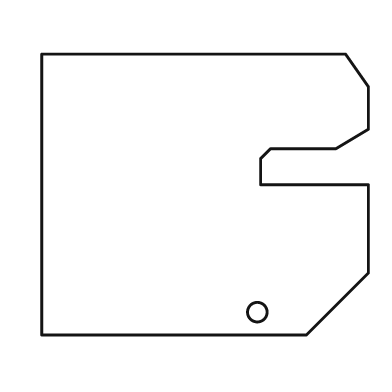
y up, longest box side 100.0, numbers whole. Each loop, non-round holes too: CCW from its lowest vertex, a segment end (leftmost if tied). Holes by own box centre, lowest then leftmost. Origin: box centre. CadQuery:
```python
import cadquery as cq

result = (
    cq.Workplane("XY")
    .moveTo(-50.0, -43.0)
    .lineTo(31.0, -43.0)
    .lineTo(50.0, -24.0)
    .lineTo(50.0, 3.0)
    .lineTo(17.0, 3.0)
    .lineTo(17.0, 11.0)
    .lineTo(20.0, 14.0)
    .lineTo(40.0, 14.0)
    .lineTo(50.0, 20.0)
    .lineTo(50.0, 33.0)
    .lineTo(43.0, 43.0)
    .lineTo(-50.0, 43.0)
    .close()
    .moveTo(16.0, -36.0)
    .circle(3.0)
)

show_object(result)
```